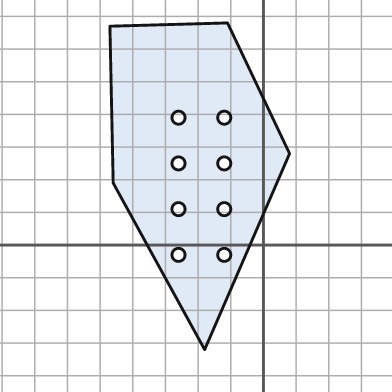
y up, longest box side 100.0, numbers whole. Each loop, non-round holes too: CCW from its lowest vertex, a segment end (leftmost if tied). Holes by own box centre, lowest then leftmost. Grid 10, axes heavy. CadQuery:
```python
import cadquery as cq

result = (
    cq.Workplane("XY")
    .moveTo(-18.0, -32.0)
    .lineTo(8.0, 28.0)
    .lineTo(-11.0, 68.0)
    .lineTo(-47.0, 67.0)
    .lineTo(-46.0, 19.0)
    .close()
    .moveTo(-26.0, -3.0)
    .circle(2.0)
    .moveTo(-12.0, -3.0)
    .circle(2.0)
    .moveTo(-26.0, 11.0)
    .circle(2.0)
    .moveTo(-12.0, 11.0)
    .circle(2.0)
    .moveTo(-26.0, 25.0)
    .circle(2.0)
    .moveTo(-12.0, 25.0)
    .circle(2.0)
    .moveTo(-26.0, 39.0)
    .circle(2.0)
    .moveTo(-12.0, 39.0)
    .circle(2.0)
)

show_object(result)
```